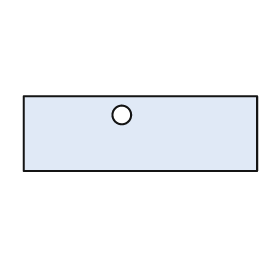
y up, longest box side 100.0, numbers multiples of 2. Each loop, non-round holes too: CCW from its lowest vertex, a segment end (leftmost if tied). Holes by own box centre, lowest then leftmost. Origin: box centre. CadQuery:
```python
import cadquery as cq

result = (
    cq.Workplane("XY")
    .moveTo(-50.0, -16.0)
    .lineTo(50.0, -16.0)
    .lineTo(50.0, 16.0)
    .lineTo(-50.0, 16.0)
    .close()
    .moveTo(-8.0, 8.0)
    .circle(4.0)
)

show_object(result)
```